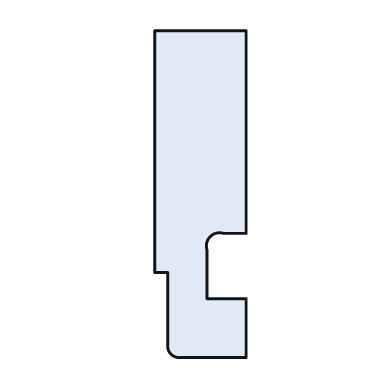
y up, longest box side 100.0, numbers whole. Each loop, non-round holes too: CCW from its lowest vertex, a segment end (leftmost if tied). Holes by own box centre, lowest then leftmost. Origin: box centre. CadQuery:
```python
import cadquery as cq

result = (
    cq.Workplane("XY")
    .moveTo(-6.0, -50.0)
    .lineTo(14.0, -50.0)
    .lineTo(14.0, -32.0)
    .lineTo(2.0, -32.0)
    .lineTo(2.0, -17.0)
    .threePointArc((3.0, -13.0), (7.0, -12.0))
    .lineTo(14.0, -12.0)
    .lineTo(14.0, 50.0)
    .lineTo(-14.0, 50.0)
    .lineTo(-14.0, -24.0)
    .lineTo(-10.0, -24.0)
    .lineTo(-10.0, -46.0)
    .threePointArc((-9.0, -49.0), (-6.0, -50.0))
    .close()
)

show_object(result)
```